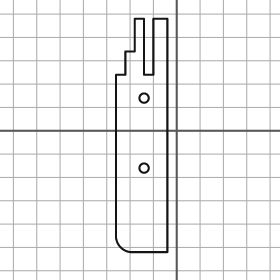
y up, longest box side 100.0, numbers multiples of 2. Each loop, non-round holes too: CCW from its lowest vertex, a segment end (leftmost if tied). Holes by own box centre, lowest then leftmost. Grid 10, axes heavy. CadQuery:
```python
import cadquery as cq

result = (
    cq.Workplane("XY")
    .moveTo(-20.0, -52.0)
    .lineTo(-4.0, -52.0)
    .lineTo(-4.0, 48.0)
    .lineTo(-10.0, 48.0)
    .lineTo(-10.0, 24.0)
    .lineTo(-14.0, 24.0)
    .lineTo(-14.0, 48.0)
    .lineTo(-18.0, 48.0)
    .lineTo(-18.0, 34.0)
    .lineTo(-22.0, 34.0)
    .lineTo(-22.0, 24.0)
    .lineTo(-26.0, 24.0)
    .lineTo(-26.0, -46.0)
    .threePointArc((-24.0, -50.0), (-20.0, -52.0))
    .close()
    .moveTo(-14.0, -16.0)
    .circle(2.0)
    .moveTo(-14.0, 14.0)
    .circle(2.0)
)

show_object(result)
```